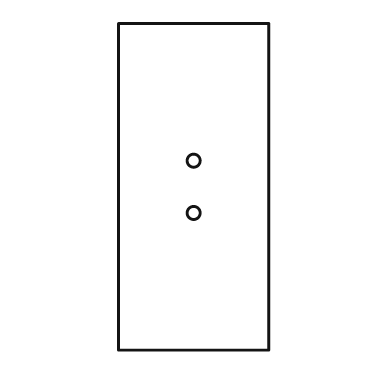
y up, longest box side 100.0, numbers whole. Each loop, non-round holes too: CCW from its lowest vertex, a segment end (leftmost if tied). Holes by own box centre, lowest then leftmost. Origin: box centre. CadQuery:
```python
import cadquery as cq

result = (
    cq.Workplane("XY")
    .moveTo(-23.0, -50.0)
    .lineTo(23.0, -50.0)
    .lineTo(23.0, 50.0)
    .lineTo(-23.0, 50.0)
    .close()
    .moveTo(0.0, -8.0)
    .circle(2.0)
    .moveTo(0.0, 8.0)
    .circle(2.0)
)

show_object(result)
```